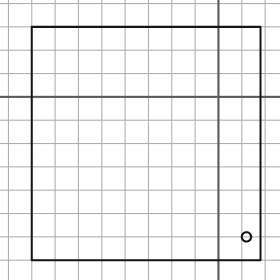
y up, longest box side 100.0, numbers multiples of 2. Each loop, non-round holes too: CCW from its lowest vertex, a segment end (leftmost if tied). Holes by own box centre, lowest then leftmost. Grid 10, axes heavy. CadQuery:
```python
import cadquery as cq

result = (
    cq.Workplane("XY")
    .moveTo(-80.0, -70.0)
    .lineTo(18.0, -70.0)
    .lineTo(18.0, 30.0)
    .lineTo(-80.0, 30.0)
    .close()
    .moveTo(12.0, -60.0)
    .circle(2.0)
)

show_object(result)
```